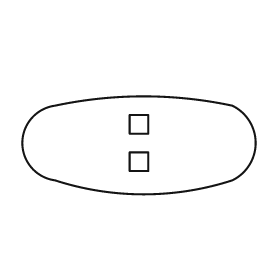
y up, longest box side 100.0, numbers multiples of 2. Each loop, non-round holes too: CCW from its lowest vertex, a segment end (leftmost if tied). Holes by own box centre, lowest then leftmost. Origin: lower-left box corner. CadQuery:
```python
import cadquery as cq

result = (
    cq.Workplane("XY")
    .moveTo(14.0, 6.0)
    .threePointArc((52.0, 0.0), (90.0, 6.0))
    .threePointArc((100.0, 22.0), (90.0, 38.0))
    .threePointArc((52.0, 42.0), (14.0, 38.0))
    .threePointArc((0.0, 22.0), (14.0, 6.0))
    .close()
    .moveTo(46.0, 10.0)
    .lineTo(54.0, 10.0)
    .lineTo(54.0, 18.0)
    .lineTo(46.0, 18.0)
    .close()
    .moveTo(46.0, 26.0)
    .lineTo(54.0, 26.0)
    .lineTo(54.0, 34.0)
    .lineTo(46.0, 34.0)
    .close()
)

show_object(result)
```